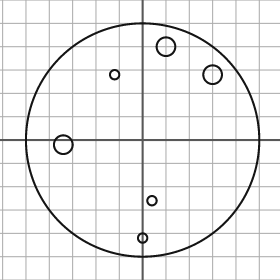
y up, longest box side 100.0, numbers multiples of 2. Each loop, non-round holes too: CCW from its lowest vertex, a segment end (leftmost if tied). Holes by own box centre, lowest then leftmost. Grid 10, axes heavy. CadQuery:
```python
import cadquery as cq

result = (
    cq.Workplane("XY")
    .moveTo(0.0, 0.0)
    .circle(50.0)
    .moveTo(0.0, -42.0)
    .circle(2.0)
    .moveTo(4.0, -26.0)
    .circle(2.0)
    .moveTo(-34.0, -2.0)
    .circle(4.0)
    .moveTo(-12.0, 28.0)
    .circle(2.0)
    .moveTo(30.0, 28.0)
    .circle(4.0)
    .moveTo(10.0, 40.0)
    .circle(4.0)
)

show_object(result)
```